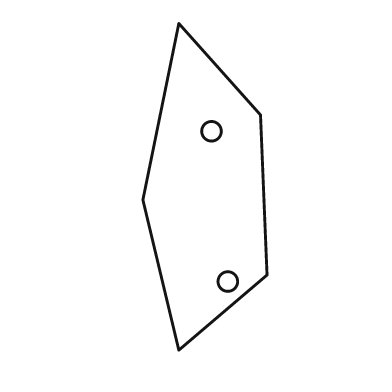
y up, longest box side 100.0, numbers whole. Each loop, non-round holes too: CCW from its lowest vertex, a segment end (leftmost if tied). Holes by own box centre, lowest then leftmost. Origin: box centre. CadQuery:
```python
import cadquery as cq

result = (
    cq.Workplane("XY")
    .moveTo(-8.0, -50.0)
    .lineTo(19.0, -27.0)
    .lineTo(17.0, 22.0)
    .lineTo(-8.0, 50.0)
    .lineTo(-19.0, -4.0)
    .close()
    .moveTo(7.0, -29.0)
    .circle(3.0)
    .moveTo(2.0, 17.0)
    .circle(3.0)
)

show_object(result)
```